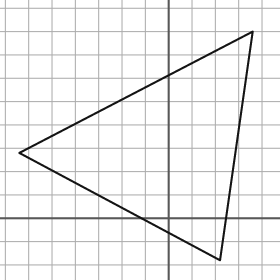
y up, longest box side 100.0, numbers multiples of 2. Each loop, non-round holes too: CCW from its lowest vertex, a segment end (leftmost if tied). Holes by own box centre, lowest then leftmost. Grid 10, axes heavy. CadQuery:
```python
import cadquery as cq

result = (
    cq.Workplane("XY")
    .moveTo(22.0, -18.0)
    .lineTo(36.0, 80.0)
    .lineTo(-64.0, 28.0)
    .close()
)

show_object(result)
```